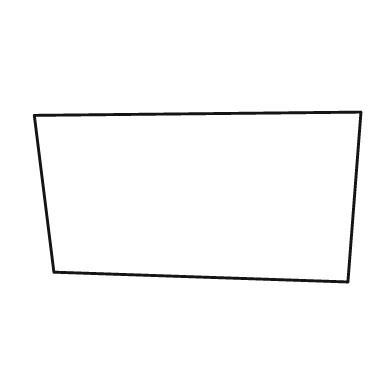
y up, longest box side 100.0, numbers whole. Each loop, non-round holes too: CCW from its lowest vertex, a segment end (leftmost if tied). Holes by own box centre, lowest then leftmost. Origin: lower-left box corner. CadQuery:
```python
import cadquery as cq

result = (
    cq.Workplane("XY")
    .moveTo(96.0, 0.0)
    .lineTo(100.0, 52.0)
    .lineTo(0.0, 51.0)
    .lineTo(6.0, 3.0)
    .close()
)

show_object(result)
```